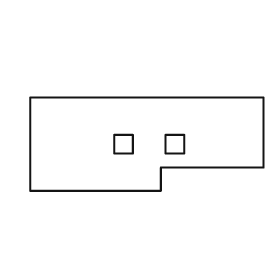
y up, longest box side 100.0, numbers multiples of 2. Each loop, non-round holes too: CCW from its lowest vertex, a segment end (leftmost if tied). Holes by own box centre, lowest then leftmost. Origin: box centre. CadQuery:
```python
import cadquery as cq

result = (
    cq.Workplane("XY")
    .moveTo(-50.0, -20.0)
    .lineTo(6.0, -20.0)
    .lineTo(6.0, -10.0)
    .lineTo(50.0, -10.0)
    .lineTo(50.0, 20.0)
    .lineTo(-50.0, 20.0)
    .close()
    .moveTo(-14.0, -4.0)
    .lineTo(-6.0, -4.0)
    .lineTo(-6.0, 4.0)
    .lineTo(-14.0, 4.0)
    .close()
    .moveTo(8.0, -4.0)
    .lineTo(16.0, -4.0)
    .lineTo(16.0, 4.0)
    .lineTo(8.0, 4.0)
    .close()
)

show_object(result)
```